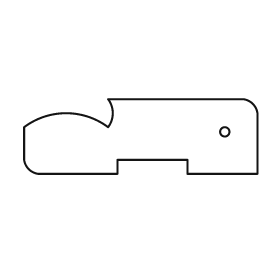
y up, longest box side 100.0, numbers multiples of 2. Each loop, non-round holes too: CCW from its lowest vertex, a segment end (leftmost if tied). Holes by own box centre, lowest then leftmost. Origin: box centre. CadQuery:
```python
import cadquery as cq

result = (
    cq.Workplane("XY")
    .moveTo(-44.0, -16.0)
    .lineTo(-10.0, -16.0)
    .lineTo(-10.0, -10.0)
    .lineTo(20.0, -10.0)
    .lineTo(20.0, -16.0)
    .lineTo(50.0, -16.0)
    .lineTo(50.0, 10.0)
    .threePointArc((48.0, 14.0), (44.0, 16.0))
    .lineTo(-14.0, 16.0)
    .threePointArc((-12.0, 10.0), (-14.0, 4.0))
    .threePointArc((-32.0, 10.0), (-50.0, 4.0))
    .lineTo(-50.0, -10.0)
    .threePointArc((-48.0, -14.0), (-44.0, -16.0))
    .close()
    .moveTo(36.0, 2.0)
    .circle(2.0)
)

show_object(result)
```